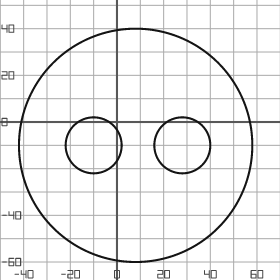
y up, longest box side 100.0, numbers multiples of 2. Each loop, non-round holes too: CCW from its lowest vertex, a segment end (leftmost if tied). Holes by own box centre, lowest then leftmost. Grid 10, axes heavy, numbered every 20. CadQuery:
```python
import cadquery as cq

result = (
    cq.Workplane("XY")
    .moveTo(8.0, -10.0)
    .circle(50.0)
    .moveTo(-10.0, -10.0)
    .circle(12.0)
    .moveTo(28.0, -10.0)
    .circle(12.0)
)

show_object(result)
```